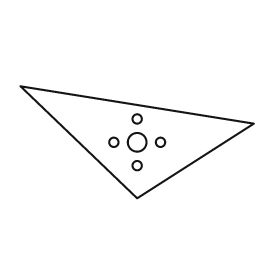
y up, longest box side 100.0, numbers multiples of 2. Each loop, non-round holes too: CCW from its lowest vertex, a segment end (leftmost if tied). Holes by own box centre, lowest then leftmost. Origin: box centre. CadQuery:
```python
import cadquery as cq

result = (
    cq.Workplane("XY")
    .moveTo(0.0, -24.0)
    .lineTo(50.0, 8.0)
    .lineTo(-50.0, 24.0)
    .close()
    .moveTo(0.0, -10.0)
    .circle(2.0)
    .moveTo(-10.0, 0.0)
    .circle(2.0)
    .moveTo(0.0, 0.0)
    .circle(4.0)
    .moveTo(10.0, 0.0)
    .circle(2.0)
    .moveTo(0.0, 10.0)
    .circle(2.0)
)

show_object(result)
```